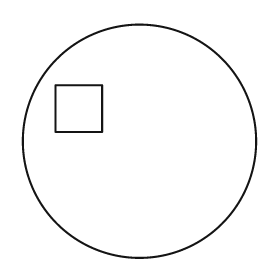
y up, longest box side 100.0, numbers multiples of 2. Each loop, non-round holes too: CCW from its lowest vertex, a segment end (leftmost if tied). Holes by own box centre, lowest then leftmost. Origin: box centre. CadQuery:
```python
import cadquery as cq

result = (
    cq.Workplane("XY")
    .moveTo(0.0, 0.0)
    .circle(50.0)
    .moveTo(-36.0, 4.0)
    .lineTo(-16.0, 4.0)
    .lineTo(-16.0, 24.0)
    .lineTo(-36.0, 24.0)
    .close()
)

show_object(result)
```